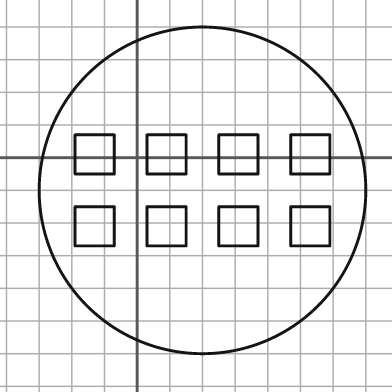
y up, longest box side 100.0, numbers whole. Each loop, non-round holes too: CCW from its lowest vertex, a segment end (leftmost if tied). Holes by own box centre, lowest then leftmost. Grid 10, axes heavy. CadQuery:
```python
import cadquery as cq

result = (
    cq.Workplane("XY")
    .moveTo(20.0, -10.0)
    .circle(50.0)
    .moveTo(-19.0, -27.0)
    .lineTo(-7.0, -27.0)
    .lineTo(-7.0, -15.0)
    .lineTo(-19.0, -15.0)
    .close()
    .moveTo(3.0, -27.0)
    .lineTo(15.0, -27.0)
    .lineTo(15.0, -15.0)
    .lineTo(3.0, -15.0)
    .close()
    .moveTo(25.0, -27.0)
    .lineTo(37.0, -27.0)
    .lineTo(37.0, -15.0)
    .lineTo(25.0, -15.0)
    .close()
    .moveTo(47.0, -27.0)
    .lineTo(59.0, -27.0)
    .lineTo(59.0, -15.0)
    .lineTo(47.0, -15.0)
    .close()
    .moveTo(-19.0, -5.0)
    .lineTo(-7.0, -5.0)
    .lineTo(-7.0, 7.0)
    .lineTo(-19.0, 7.0)
    .close()
    .moveTo(3.0, -5.0)
    .lineTo(15.0, -5.0)
    .lineTo(15.0, 7.0)
    .lineTo(3.0, 7.0)
    .close()
    .moveTo(25.0, -5.0)
    .lineTo(37.0, -5.0)
    .lineTo(37.0, 7.0)
    .lineTo(25.0, 7.0)
    .close()
    .moveTo(47.0, -5.0)
    .lineTo(59.0, -5.0)
    .lineTo(59.0, 7.0)
    .lineTo(47.0, 7.0)
    .close()
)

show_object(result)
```